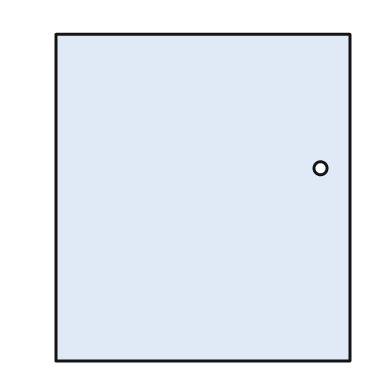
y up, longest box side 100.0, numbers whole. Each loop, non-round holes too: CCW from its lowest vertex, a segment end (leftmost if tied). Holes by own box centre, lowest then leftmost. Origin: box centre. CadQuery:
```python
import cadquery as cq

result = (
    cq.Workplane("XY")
    .moveTo(-45.0, -50.0)
    .lineTo(45.0, -50.0)
    .lineTo(45.0, 50.0)
    .lineTo(-45.0, 50.0)
    .close()
    .moveTo(36.0, 9.0)
    .circle(2.0)
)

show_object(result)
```